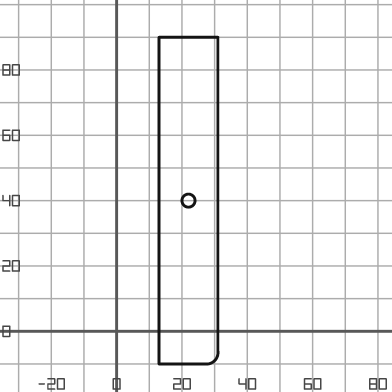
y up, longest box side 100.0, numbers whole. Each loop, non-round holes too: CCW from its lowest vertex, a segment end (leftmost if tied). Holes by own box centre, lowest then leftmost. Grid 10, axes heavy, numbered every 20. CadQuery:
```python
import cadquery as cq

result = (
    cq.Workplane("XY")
    .moveTo(13.0, -10.0)
    .lineTo(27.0, -10.0)
    .threePointArc((30.0, -9.0), (31.0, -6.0))
    .lineTo(31.0, 90.0)
    .lineTo(13.0, 90.0)
    .close()
    .moveTo(22.0, 40.0)
    .circle(2.0)
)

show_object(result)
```